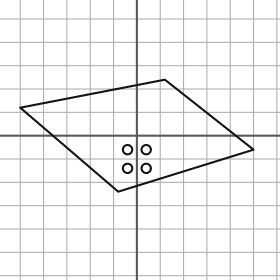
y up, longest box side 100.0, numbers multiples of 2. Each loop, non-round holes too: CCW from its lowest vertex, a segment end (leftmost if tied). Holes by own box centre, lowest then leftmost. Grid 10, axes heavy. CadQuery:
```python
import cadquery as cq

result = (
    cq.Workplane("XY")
    .moveTo(-8.0, -24.0)
    .lineTo(50.0, -6.0)
    .lineTo(12.0, 24.0)
    .lineTo(-50.0, 12.0)
    .close()
    .moveTo(-4.0, -14.0)
    .circle(2.0)
    .moveTo(4.0, -14.0)
    .circle(2.0)
    .moveTo(-4.0, -6.0)
    .circle(2.0)
    .moveTo(4.0, -6.0)
    .circle(2.0)
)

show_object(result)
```